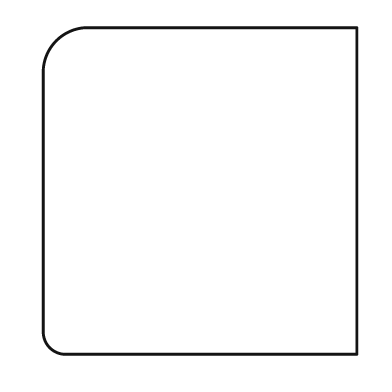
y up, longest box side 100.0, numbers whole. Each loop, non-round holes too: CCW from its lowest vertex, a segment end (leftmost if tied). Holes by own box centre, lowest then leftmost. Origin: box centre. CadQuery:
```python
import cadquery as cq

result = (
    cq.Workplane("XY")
    .moveTo(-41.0, -50.0)
    .lineTo(48.0, -50.0)
    .lineTo(48.0, 50.0)
    .lineTo(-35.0, 50.0)
    .threePointArc((-44.0, 46.0), (-48.0, 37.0))
    .lineTo(-48.0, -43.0)
    .threePointArc((-46.0, -48.0), (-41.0, -50.0))
    .close()
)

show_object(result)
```